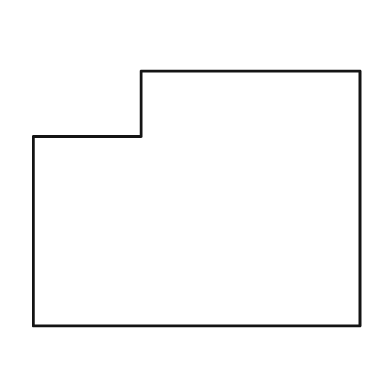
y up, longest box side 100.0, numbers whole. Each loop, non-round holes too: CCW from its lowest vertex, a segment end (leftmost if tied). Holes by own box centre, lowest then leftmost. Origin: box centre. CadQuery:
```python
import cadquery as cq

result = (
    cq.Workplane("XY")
    .moveTo(-50.0, -39.0)
    .lineTo(50.0, -39.0)
    .lineTo(50.0, 39.0)
    .lineTo(-17.0, 39.0)
    .lineTo(-17.0, 19.0)
    .lineTo(-50.0, 19.0)
    .close()
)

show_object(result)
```